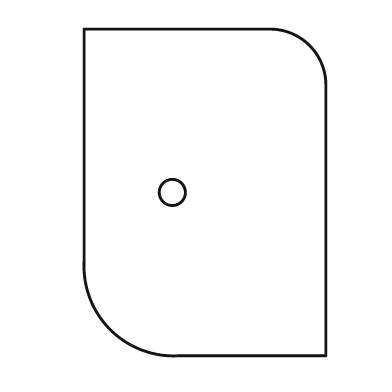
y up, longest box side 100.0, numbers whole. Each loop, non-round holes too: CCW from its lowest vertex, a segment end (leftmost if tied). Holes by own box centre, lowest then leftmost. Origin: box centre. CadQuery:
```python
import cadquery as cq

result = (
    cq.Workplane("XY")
    .moveTo(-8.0, -50.0)
    .lineTo(37.0, -50.0)
    .lineTo(37.0, 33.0)
    .threePointArc((32.0, 45.0), (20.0, 50.0))
    .lineTo(-37.0, 50.0)
    .lineTo(-37.0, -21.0)
    .threePointArc((-29.0, -42.0), (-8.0, -50.0))
    .close()
    .moveTo(-10.0, 0.0)
    .circle(4.0)
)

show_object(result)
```